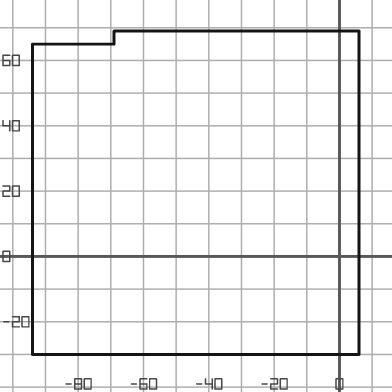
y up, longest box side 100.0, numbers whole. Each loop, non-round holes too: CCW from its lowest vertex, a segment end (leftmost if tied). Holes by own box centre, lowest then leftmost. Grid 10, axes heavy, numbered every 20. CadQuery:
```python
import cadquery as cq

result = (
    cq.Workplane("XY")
    .moveTo(-94.0, -30.0)
    .lineTo(6.0, -30.0)
    .lineTo(6.0, 69.0)
    .lineTo(-69.0, 69.0)
    .lineTo(-69.0, 65.0)
    .lineTo(-94.0, 65.0)
    .close()
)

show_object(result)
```